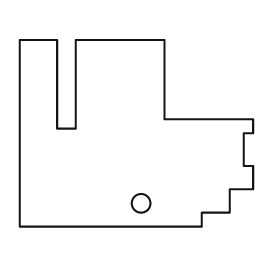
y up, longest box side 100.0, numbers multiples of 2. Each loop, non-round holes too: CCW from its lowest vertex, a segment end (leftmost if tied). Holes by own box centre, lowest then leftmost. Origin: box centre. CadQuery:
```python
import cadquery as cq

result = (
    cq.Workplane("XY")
    .moveTo(-50.0, -40.0)
    .lineTo(28.0, -40.0)
    .lineTo(28.0, -34.0)
    .lineTo(40.0, -34.0)
    .lineTo(40.0, -24.0)
    .lineTo(50.0, -24.0)
    .lineTo(50.0, -14.0)
    .lineTo(46.0, -14.0)
    .lineTo(46.0, 0.0)
    .lineTo(50.0, 0.0)
    .lineTo(50.0, 6.0)
    .lineTo(12.0, 6.0)
    .lineTo(12.0, 40.0)
    .lineTo(-26.0, 40.0)
    .lineTo(-26.0, 2.0)
    .lineTo(-34.0, 2.0)
    .lineTo(-34.0, 40.0)
    .lineTo(-50.0, 40.0)
    .close()
    .moveTo(2.0, -30.0)
    .circle(4.0)
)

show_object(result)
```